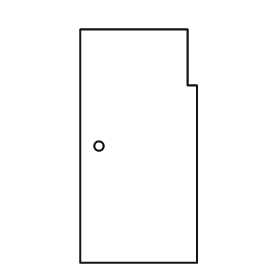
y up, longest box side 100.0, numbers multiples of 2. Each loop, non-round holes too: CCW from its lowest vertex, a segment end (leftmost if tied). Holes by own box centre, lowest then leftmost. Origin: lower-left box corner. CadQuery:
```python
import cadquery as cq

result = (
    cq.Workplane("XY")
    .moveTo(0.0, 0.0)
    .lineTo(50.0, 0.0)
    .lineTo(50.0, 76.0)
    .lineTo(46.0, 76.0)
    .lineTo(46.0, 100.0)
    .lineTo(0.0, 100.0)
    .close()
    .moveTo(8.0, 50.0)
    .circle(2.0)
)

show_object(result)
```